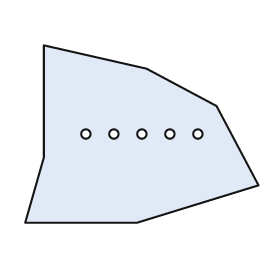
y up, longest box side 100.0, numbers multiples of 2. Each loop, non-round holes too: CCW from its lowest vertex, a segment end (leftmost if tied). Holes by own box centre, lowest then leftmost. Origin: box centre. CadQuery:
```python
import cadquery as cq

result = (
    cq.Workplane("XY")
    .moveTo(-50.0, -38.0)
    .lineTo(-2.0, -38.0)
    .lineTo(50.0, -22.0)
    .lineTo(32.0, 12.0)
    .lineTo(2.0, 28.0)
    .lineTo(-42.0, 38.0)
    .lineTo(-42.0, -10.0)
    .close()
    .moveTo(-24.0, 0.0)
    .circle(2.0)
    .moveTo(-12.0, 0.0)
    .circle(2.0)
    .moveTo(0.0, 0.0)
    .circle(2.0)
    .moveTo(12.0, 0.0)
    .circle(2.0)
    .moveTo(24.0, 0.0)
    .circle(2.0)
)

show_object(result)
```